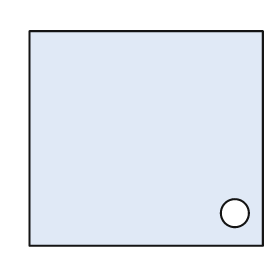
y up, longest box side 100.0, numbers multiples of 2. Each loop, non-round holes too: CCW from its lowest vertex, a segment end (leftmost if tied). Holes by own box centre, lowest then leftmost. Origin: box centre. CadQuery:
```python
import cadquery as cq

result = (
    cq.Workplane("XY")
    .moveTo(-50.0, -46.0)
    .lineTo(50.0, -46.0)
    .lineTo(50.0, 46.0)
    .lineTo(-50.0, 46.0)
    .close()
    .moveTo(38.0, -32.0)
    .circle(6.0)
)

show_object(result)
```